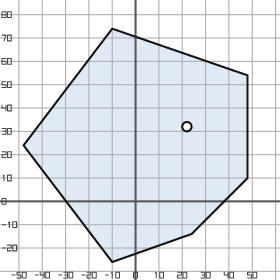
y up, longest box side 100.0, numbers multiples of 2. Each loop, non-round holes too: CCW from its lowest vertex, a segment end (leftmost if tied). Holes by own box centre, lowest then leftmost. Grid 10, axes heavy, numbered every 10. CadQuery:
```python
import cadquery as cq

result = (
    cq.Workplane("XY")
    .moveTo(-10.0, -26.0)
    .lineTo(24.0, -14.0)
    .lineTo(48.0, 10.0)
    .lineTo(48.0, 54.0)
    .lineTo(-10.0, 74.0)
    .lineTo(-48.0, 24.0)
    .close()
    .moveTo(22.0, 32.0)
    .circle(2.0)
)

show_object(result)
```